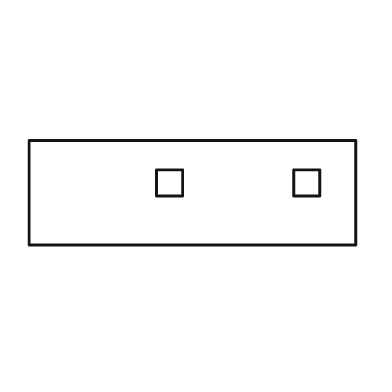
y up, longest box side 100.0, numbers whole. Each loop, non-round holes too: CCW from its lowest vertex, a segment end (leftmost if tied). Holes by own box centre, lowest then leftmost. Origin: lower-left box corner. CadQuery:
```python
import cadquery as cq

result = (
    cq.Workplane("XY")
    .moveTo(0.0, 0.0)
    .lineTo(100.0, 0.0)
    .lineTo(100.0, 32.0)
    .lineTo(0.0, 32.0)
    .close()
    .moveTo(39.0, 15.0)
    .lineTo(47.0, 15.0)
    .lineTo(47.0, 23.0)
    .lineTo(39.0, 23.0)
    .close()
    .moveTo(81.0, 15.0)
    .lineTo(89.0, 15.0)
    .lineTo(89.0, 23.0)
    .lineTo(81.0, 23.0)
    .close()
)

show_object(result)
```